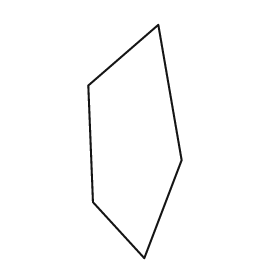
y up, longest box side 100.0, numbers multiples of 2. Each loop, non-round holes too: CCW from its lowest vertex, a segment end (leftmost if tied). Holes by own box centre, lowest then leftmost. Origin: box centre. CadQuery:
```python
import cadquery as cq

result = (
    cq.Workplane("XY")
    .moveTo(4.0, -50.0)
    .lineTo(20.0, -8.0)
    .lineTo(10.0, 50.0)
    .lineTo(-20.0, 24.0)
    .lineTo(-18.0, -26.0)
    .close()
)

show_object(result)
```